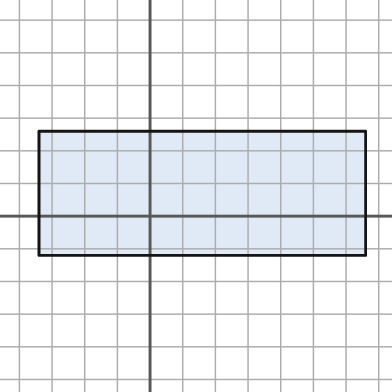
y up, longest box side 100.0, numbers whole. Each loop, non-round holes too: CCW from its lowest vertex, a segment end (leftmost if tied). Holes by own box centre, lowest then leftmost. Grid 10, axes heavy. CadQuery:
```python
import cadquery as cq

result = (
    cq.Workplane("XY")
    .moveTo(-34.0, -12.0)
    .lineTo(66.0, -12.0)
    .lineTo(66.0, 26.0)
    .lineTo(-34.0, 26.0)
    .close()
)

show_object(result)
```